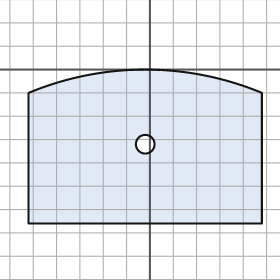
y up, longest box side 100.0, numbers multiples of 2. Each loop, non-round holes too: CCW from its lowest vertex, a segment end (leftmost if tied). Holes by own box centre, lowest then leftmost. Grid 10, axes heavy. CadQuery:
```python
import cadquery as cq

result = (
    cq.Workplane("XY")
    .moveTo(-52.0, -66.0)
    .lineTo(48.0, -66.0)
    .lineTo(48.0, -10.0)
    .threePointArc((-2.0, 0.0), (-52.0, -10.0))
    .close()
    .moveTo(-2.0, -32.0)
    .circle(4.0)
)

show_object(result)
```